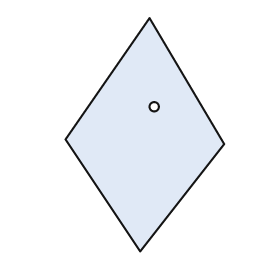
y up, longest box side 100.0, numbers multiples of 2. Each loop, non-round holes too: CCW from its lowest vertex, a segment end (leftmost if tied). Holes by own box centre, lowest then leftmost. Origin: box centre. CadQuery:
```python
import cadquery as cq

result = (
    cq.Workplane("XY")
    .moveTo(-2.0, -50.0)
    .lineTo(34.0, -4.0)
    .lineTo(2.0, 50.0)
    .lineTo(-34.0, -2.0)
    .close()
    .moveTo(4.0, 12.0)
    .circle(2.0)
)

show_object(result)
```